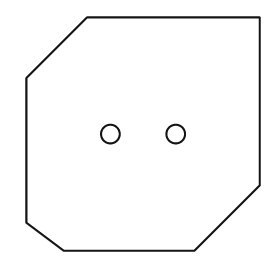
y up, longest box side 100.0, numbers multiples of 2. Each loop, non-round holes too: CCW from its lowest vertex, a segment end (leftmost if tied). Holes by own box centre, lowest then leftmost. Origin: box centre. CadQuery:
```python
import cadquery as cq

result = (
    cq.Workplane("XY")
    .moveTo(-34.0, -50.0)
    .lineTo(22.0, -50.0)
    .lineTo(50.0, -22.0)
    .lineTo(50.0, 50.0)
    .lineTo(-24.0, 50.0)
    .lineTo(-50.0, 24.0)
    .lineTo(-50.0, -38.0)
    .close()
    .moveTo(-14.0, 0.0)
    .circle(4.0)
    .moveTo(14.0, 0.0)
    .circle(4.0)
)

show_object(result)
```